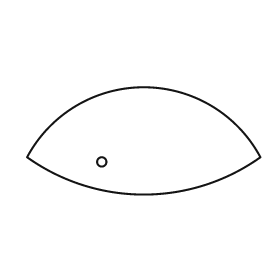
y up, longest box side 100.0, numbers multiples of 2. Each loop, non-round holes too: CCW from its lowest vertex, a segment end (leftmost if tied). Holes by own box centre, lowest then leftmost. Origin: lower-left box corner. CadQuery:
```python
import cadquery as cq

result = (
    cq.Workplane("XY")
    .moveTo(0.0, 16.0)
    .threePointArc((50.0, 0.0), (100.0, 16.0))
    .threePointArc((50.0, 46.0), (0.0, 16.0))
    .close()
    .moveTo(32.0, 14.0)
    .circle(2.0)
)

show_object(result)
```